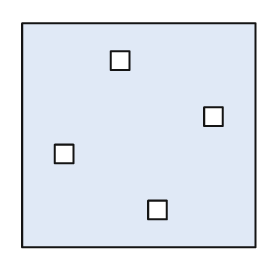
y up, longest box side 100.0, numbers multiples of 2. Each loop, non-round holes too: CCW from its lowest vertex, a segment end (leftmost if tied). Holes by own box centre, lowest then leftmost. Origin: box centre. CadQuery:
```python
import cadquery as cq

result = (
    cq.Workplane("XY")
    .moveTo(-50.0, -48.0)
    .lineTo(50.0, -48.0)
    .lineTo(50.0, 48.0)
    .lineTo(-50.0, 48.0)
    .close()
    .moveTo(4.0, -36.0)
    .lineTo(12.0, -36.0)
    .lineTo(12.0, -28.0)
    .lineTo(4.0, -28.0)
    .close()
    .moveTo(-36.0, -12.0)
    .lineTo(-28.0, -12.0)
    .lineTo(-28.0, -4.0)
    .lineTo(-36.0, -4.0)
    .close()
    .moveTo(28.0, 4.0)
    .lineTo(36.0, 4.0)
    .lineTo(36.0, 12.0)
    .lineTo(28.0, 12.0)
    .close()
    .moveTo(-12.0, 28.0)
    .lineTo(-4.0, 28.0)
    .lineTo(-4.0, 36.0)
    .lineTo(-12.0, 36.0)
    .close()
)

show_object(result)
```